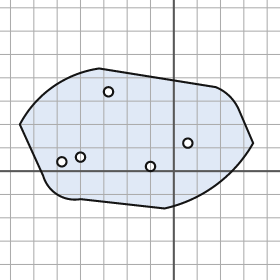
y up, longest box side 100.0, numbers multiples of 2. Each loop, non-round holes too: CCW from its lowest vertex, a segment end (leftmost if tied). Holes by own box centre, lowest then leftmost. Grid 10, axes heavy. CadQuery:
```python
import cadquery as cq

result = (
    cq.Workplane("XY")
    .moveTo(-4.0, -16.0)
    .threePointArc((18.0, -6.0), (34.0, 12.0))
    .lineTo(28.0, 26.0)
    .threePointArc((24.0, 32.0), (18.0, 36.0))
    .lineTo(-32.0, 44.0)
    .threePointArc((-52.0, 36.0), (-66.0, 20.0))
    .lineTo(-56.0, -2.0)
    .threePointArc((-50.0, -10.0), (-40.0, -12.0))
    .close()
    .moveTo(-10.0, 2.0)
    .circle(2.0)
    .moveTo(-48.0, 4.0)
    .circle(2.0)
    .moveTo(-40.0, 6.0)
    .circle(2.0)
    .moveTo(6.0, 12.0)
    .circle(2.0)
    .moveTo(-28.0, 34.0)
    .circle(2.0)
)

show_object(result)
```